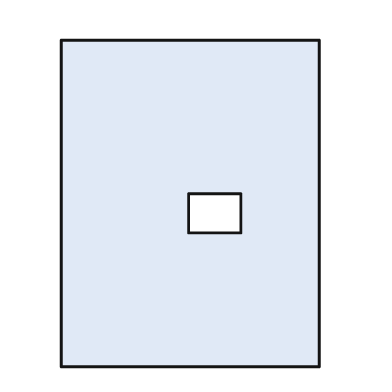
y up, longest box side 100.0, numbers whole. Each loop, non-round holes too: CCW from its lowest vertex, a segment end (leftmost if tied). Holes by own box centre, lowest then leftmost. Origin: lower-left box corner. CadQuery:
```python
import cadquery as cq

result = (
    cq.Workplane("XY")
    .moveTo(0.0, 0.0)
    .lineTo(79.0, 0.0)
    .lineTo(79.0, 100.0)
    .lineTo(0.0, 100.0)
    .close()
    .moveTo(39.0, 41.0)
    .lineTo(55.0, 41.0)
    .lineTo(55.0, 53.0)
    .lineTo(39.0, 53.0)
    .close()
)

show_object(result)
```